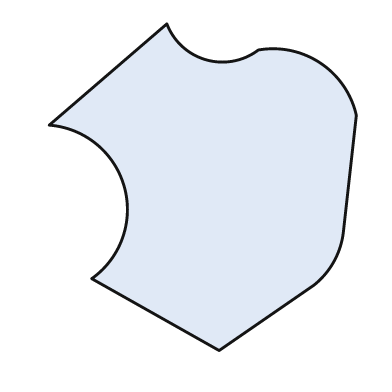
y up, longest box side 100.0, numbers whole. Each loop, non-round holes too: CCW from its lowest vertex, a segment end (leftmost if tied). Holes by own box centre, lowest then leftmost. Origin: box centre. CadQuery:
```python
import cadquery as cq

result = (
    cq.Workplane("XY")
    .moveTo(5.0, -50.0)
    .lineTo(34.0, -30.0)
    .threePointArc((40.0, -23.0), (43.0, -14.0))
    .lineTo(47.0, 22.0)
    .threePointArc((36.0, 38.0), (17.0, 42.0))
    .threePointArc((1.0, 39.0), (-11.0, 50.0))
    .lineTo(-47.0, 19.0)
    .threePointArc((-24.0, 0.0), (-34.0, -28.0))
    .close()
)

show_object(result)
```